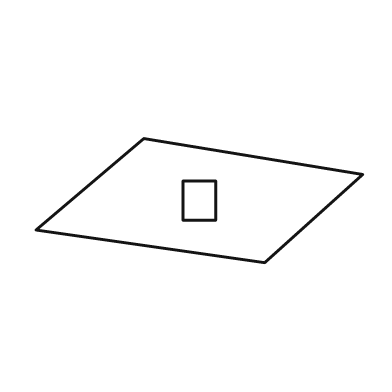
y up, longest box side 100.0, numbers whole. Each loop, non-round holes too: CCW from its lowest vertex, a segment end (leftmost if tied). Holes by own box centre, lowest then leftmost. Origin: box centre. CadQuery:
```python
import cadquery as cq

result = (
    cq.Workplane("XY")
    .moveTo(20.0, -19.0)
    .lineTo(50.0, 8.0)
    .lineTo(-17.0, 19.0)
    .lineTo(-50.0, -9.0)
    .close()
    .moveTo(-5.0, -6.0)
    .lineTo(5.0, -6.0)
    .lineTo(5.0, 6.0)
    .lineTo(-5.0, 6.0)
    .close()
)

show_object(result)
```